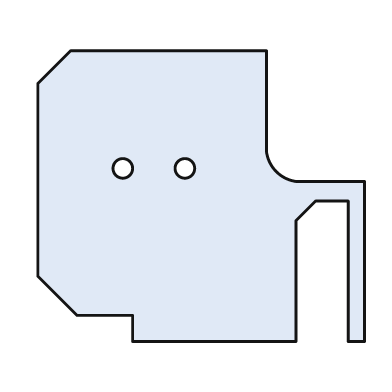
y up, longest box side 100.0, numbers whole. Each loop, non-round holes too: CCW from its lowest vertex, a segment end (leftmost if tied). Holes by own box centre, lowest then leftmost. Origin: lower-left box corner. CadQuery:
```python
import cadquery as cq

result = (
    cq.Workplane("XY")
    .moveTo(29.0, 0.0)
    .lineTo(79.0, 0.0)
    .lineTo(79.0, 37.0)
    .lineTo(85.0, 43.0)
    .lineTo(95.0, 43.0)
    .lineTo(95.0, 0.0)
    .lineTo(100.0, 0.0)
    .lineTo(100.0, 49.0)
    .lineTo(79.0, 49.0)
    .threePointArc((73.0, 52.0), (70.0, 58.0))
    .lineTo(70.0, 89.0)
    .lineTo(10.0, 89.0)
    .lineTo(0.0, 79.0)
    .lineTo(0.0, 20.0)
    .lineTo(12.0, 8.0)
    .lineTo(29.0, 8.0)
    .close()
    .moveTo(26.0, 53.0)
    .circle(3.0)
    .moveTo(45.0, 53.0)
    .circle(3.0)
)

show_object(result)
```